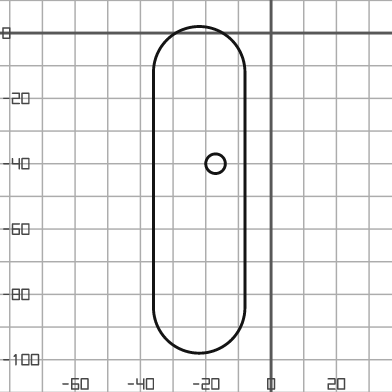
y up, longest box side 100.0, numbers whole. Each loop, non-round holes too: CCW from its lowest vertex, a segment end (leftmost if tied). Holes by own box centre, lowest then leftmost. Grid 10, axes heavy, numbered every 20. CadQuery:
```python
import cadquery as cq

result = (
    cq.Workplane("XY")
    .moveTo(-36.0, -84.0)
    .threePointArc((-22.0, -98.0), (-8.0, -84.0))
    .lineTo(-8.0, -12.0)
    .threePointArc((-22.0, 2.0), (-36.0, -12.0))
    .close()
    .moveTo(-17.0, -40.0)
    .circle(3.0)
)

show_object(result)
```